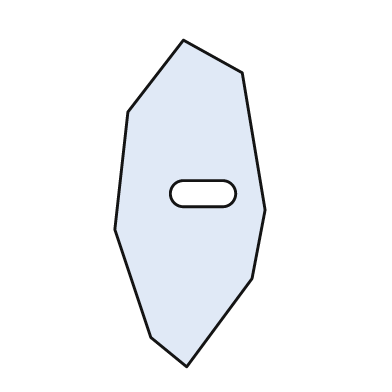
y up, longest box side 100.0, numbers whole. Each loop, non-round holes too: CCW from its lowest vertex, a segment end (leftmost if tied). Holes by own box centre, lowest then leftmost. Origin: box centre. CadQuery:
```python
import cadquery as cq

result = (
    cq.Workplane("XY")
    .moveTo(-1.0, -50.0)
    .lineTo(19.0, -23.0)
    .lineTo(23.0, -2.0)
    .lineTo(16.0, 40.0)
    .lineTo(-2.0, 50.0)
    .lineTo(-19.0, 28.0)
    .lineTo(-23.0, -8.0)
    .lineTo(-12.0, -41.0)
    .close()
    .moveTo(-2.0, -1.0)
    .lineTo(10.0, -1.0)
    .threePointArc((14.0, 3.0), (10.0, 7.0))
    .lineTo(-2.0, 7.0)
    .threePointArc((-6.0, 3.0), (-2.0, -1.0))
    .close()
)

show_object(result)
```